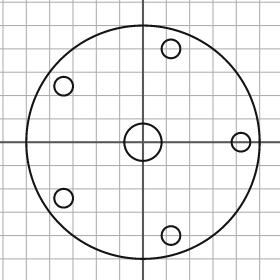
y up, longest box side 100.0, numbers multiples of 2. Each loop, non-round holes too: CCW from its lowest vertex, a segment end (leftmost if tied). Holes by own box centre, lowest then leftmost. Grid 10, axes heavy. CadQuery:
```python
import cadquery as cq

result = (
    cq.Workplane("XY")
    .moveTo(0.0, 0.0)
    .circle(50.0)
    .moveTo(12.0, -40.0)
    .circle(4.0)
    .moveTo(-34.0, -24.0)
    .circle(4.0)
    .moveTo(0.0, 0.0)
    .circle(8.0)
    .moveTo(42.0, 0.0)
    .circle(4.0)
    .moveTo(-34.0, 24.0)
    .circle(4.0)
    .moveTo(12.0, 40.0)
    .circle(4.0)
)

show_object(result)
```